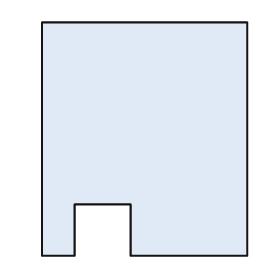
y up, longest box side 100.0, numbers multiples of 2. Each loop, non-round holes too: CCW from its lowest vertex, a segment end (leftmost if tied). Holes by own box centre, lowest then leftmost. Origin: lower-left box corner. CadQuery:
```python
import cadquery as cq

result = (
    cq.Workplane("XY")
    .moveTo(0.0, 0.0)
    .lineTo(14.0, 0.0)
    .lineTo(14.0, 22.0)
    .lineTo(38.0, 22.0)
    .lineTo(38.0, 0.0)
    .lineTo(88.0, 0.0)
    .lineTo(88.0, 100.0)
    .lineTo(0.0, 100.0)
    .close()
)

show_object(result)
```